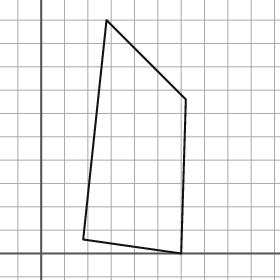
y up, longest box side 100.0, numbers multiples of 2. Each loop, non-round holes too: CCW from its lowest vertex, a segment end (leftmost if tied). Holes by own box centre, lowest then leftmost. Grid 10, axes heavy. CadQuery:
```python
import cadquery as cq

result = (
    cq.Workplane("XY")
    .moveTo(60.0, 0.0)
    .lineTo(62.0, 66.0)
    .lineTo(28.0, 100.0)
    .lineTo(18.0, 6.0)
    .close()
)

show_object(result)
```